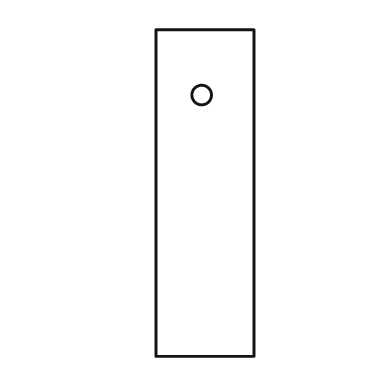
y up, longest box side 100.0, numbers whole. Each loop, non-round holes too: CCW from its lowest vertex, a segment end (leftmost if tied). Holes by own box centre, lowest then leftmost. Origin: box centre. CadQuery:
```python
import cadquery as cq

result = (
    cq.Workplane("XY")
    .moveTo(-15.0, -50.0)
    .lineTo(15.0, -50.0)
    .lineTo(15.0, 50.0)
    .lineTo(-15.0, 50.0)
    .close()
    .moveTo(-1.0, 30.0)
    .circle(3.0)
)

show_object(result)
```